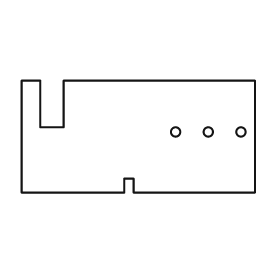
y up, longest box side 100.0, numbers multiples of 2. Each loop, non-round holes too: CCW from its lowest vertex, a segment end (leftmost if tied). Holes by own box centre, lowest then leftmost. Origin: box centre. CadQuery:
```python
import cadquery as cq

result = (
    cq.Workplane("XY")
    .moveTo(-50.0, -24.0)
    .lineTo(-6.0, -24.0)
    .lineTo(-6.0, -18.0)
    .lineTo(-2.0, -18.0)
    .lineTo(-2.0, -24.0)
    .lineTo(50.0, -24.0)
    .lineTo(50.0, 24.0)
    .lineTo(-32.0, 24.0)
    .lineTo(-32.0, 4.0)
    .lineTo(-42.0, 4.0)
    .lineTo(-42.0, 24.0)
    .lineTo(-50.0, 24.0)
    .close()
    .moveTo(16.0, 2.0)
    .circle(2.0)
    .moveTo(30.0, 2.0)
    .circle(2.0)
    .moveTo(44.0, 2.0)
    .circle(2.0)
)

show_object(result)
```